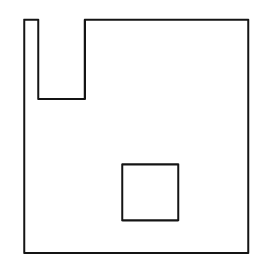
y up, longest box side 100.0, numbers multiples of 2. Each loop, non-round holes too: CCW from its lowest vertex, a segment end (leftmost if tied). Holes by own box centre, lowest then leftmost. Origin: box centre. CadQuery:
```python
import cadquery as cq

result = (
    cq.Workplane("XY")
    .moveTo(-48.0, -50.0)
    .lineTo(48.0, -50.0)
    .lineTo(48.0, 50.0)
    .lineTo(-22.0, 50.0)
    .lineTo(-22.0, 16.0)
    .lineTo(-42.0, 16.0)
    .lineTo(-42.0, 50.0)
    .lineTo(-48.0, 50.0)
    .close()
    .moveTo(-6.0, -36.0)
    .lineTo(18.0, -36.0)
    .lineTo(18.0, -12.0)
    .lineTo(-6.0, -12.0)
    .close()
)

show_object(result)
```